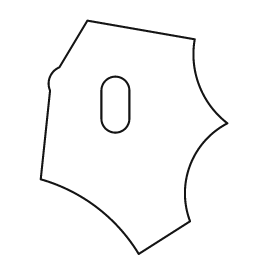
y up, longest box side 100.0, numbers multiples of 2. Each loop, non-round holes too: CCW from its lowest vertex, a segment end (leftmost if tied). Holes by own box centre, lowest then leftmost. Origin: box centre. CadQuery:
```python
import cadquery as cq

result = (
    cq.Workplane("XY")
    .moveTo(2.0, -50.0)
    .lineTo(24.0, -36.0)
    .threePointArc((24.0, -12.0), (40.0, 6.0))
    .threePointArc((28.0, 22.0), (26.0, 42.0))
    .lineTo(-20.0, 50.0)
    .lineTo(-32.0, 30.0)
    .threePointArc((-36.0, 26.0), (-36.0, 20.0))
    .lineTo(-40.0, -18.0)
    .threePointArc((-16.0, -30.0), (2.0, -50.0))
    .close()
    .moveTo(-14.0, 8.0)
    .threePointArc((-8.0, 2.0), (-2.0, 8.0))
    .lineTo(-2.0, 20.0)
    .threePointArc((-8.0, 26.0), (-14.0, 20.0))
    .close()
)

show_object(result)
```